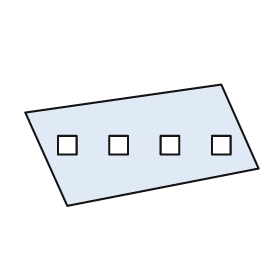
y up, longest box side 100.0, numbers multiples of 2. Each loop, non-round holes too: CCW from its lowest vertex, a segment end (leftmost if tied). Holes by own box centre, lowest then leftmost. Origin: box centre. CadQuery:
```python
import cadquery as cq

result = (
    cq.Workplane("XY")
    .moveTo(-32.0, -26.0)
    .lineTo(50.0, -10.0)
    .lineTo(34.0, 26.0)
    .lineTo(-50.0, 14.0)
    .close()
    .moveTo(-36.0, -4.0)
    .lineTo(-28.0, -4.0)
    .lineTo(-28.0, 4.0)
    .lineTo(-36.0, 4.0)
    .close()
    .moveTo(-14.0, -4.0)
    .lineTo(-6.0, -4.0)
    .lineTo(-6.0, 4.0)
    .lineTo(-14.0, 4.0)
    .close()
    .moveTo(8.0, -4.0)
    .lineTo(16.0, -4.0)
    .lineTo(16.0, 4.0)
    .lineTo(8.0, 4.0)
    .close()
    .moveTo(30.0, -4.0)
    .lineTo(38.0, -4.0)
    .lineTo(38.0, 4.0)
    .lineTo(30.0, 4.0)
    .close()
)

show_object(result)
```